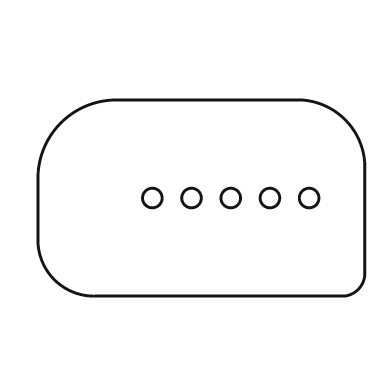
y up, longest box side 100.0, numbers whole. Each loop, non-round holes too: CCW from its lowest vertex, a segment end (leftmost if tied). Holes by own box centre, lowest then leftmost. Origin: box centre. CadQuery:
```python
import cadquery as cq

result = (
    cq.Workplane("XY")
    .moveTo(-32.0, -30.0)
    .lineTo(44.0, -30.0)
    .threePointArc((48.0, -28.0), (50.0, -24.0))
    .lineTo(50.0, 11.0)
    .threePointArc((44.0, 24.0), (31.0, 30.0))
    .lineTo(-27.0, 30.0)
    .threePointArc((-43.0, 23.0), (-50.0, 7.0))
    .lineTo(-50.0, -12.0)
    .threePointArc((-45.0, -25.0), (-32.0, -30.0))
    .close()
    .moveTo(-15.0, 0.0)
    .circle(3.0)
    .moveTo(-3.0, 0.0)
    .circle(3.0)
    .moveTo(9.0, 0.0)
    .circle(3.0)
    .moveTo(21.0, 0.0)
    .circle(3.0)
    .moveTo(33.0, 0.0)
    .circle(3.0)
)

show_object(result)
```